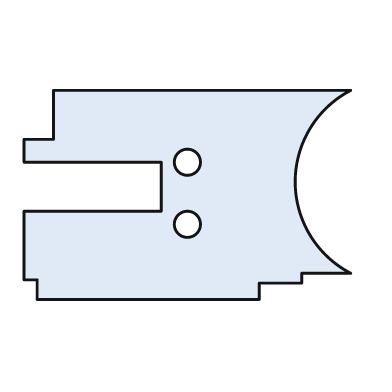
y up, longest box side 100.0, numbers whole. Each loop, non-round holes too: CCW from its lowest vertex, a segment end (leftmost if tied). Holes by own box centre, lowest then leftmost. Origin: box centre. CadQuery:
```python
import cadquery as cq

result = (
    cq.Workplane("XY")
    .moveTo(-46.0, -32.0)
    .lineTo(22.0, -32.0)
    .lineTo(22.0, -27.0)
    .lineTo(35.0, -27.0)
    .lineTo(35.0, -24.0)
    .lineTo(50.0, -24.0)
    .threePointArc((33.0, 4.0), (50.0, 32.0))
    .lineTo(-41.0, 32.0)
    .lineTo(-41.0, 17.0)
    .lineTo(-50.0, 17.0)
    .lineTo(-50.0, 10.0)
    .lineTo(-8.0, 10.0)
    .lineTo(-8.0, -5.0)
    .lineTo(-50.0, -5.0)
    .lineTo(-50.0, -26.0)
    .lineTo(-46.0, -26.0)
    .close()
    .moveTo(0.0, -9.0)
    .circle(4.0)
    .moveTo(0.0, 10.0)
    .circle(4.0)
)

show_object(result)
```